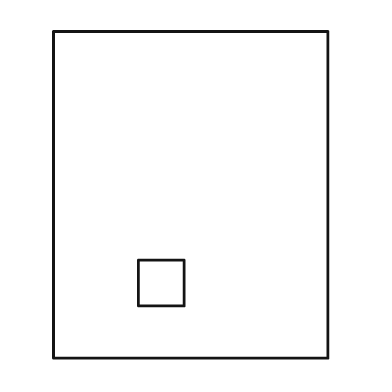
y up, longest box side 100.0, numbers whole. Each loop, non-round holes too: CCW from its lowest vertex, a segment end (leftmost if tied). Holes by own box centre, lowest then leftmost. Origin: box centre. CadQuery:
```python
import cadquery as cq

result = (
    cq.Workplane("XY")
    .moveTo(-42.0, -50.0)
    .lineTo(42.0, -50.0)
    .lineTo(42.0, 50.0)
    .lineTo(-42.0, 50.0)
    .close()
    .moveTo(-16.0, -34.0)
    .lineTo(-2.0, -34.0)
    .lineTo(-2.0, -20.0)
    .lineTo(-16.0, -20.0)
    .close()
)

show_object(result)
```